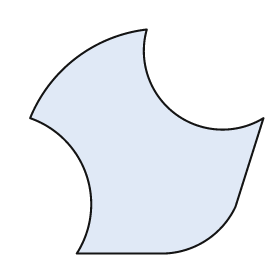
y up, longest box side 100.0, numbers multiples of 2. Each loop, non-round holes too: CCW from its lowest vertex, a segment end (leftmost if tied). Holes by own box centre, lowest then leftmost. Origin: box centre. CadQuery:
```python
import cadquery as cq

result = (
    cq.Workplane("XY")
    .moveTo(-30.0, -48.0)
    .lineTo(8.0, -48.0)
    .threePointArc((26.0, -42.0), (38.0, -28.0))
    .lineTo(50.0, 10.0)
    .threePointArc((12.0, 12.0), (0.0, 48.0))
    .threePointArc((-30.0, 36.0), (-50.0, 10.0))
    .threePointArc((-26.0, -14.0), (-30.0, -48.0))
    .close()
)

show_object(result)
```